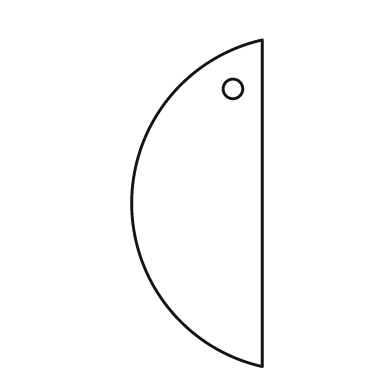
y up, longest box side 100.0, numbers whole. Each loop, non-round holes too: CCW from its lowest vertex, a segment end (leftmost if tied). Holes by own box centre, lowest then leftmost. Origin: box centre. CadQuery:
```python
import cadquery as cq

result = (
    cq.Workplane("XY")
    .moveTo(20.0, -50.0)
    .lineTo(20.0, 50.0)
    .threePointArc((-20.0, 0.0), (20.0, -50.0))
    .close()
    .moveTo(11.0, 35.0)
    .circle(3.0)
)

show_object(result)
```